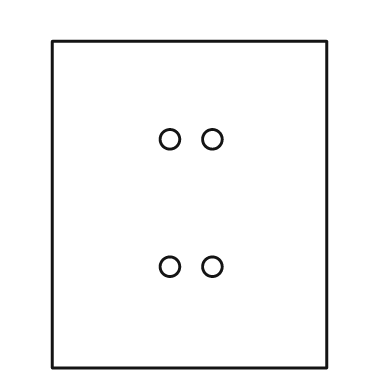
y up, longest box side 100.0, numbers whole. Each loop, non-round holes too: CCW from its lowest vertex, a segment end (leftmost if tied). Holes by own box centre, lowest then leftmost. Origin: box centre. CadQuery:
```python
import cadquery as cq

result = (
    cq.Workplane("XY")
    .moveTo(-42.0, -50.0)
    .lineTo(42.0, -50.0)
    .lineTo(42.0, 50.0)
    .lineTo(-42.0, 50.0)
    .close()
    .moveTo(-6.0, -19.0)
    .circle(3.0)
    .moveTo(7.0, -19.0)
    .circle(3.0)
    .moveTo(-6.0, 20.0)
    .circle(3.0)
    .moveTo(7.0, 20.0)
    .circle(3.0)
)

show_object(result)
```